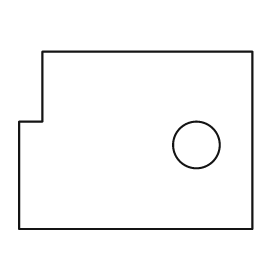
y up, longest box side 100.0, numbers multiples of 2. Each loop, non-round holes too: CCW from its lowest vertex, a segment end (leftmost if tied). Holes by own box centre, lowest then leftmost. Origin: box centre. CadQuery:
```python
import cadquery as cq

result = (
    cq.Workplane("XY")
    .moveTo(-50.0, -38.0)
    .lineTo(50.0, -38.0)
    .lineTo(50.0, 38.0)
    .lineTo(-40.0, 38.0)
    .lineTo(-40.0, 8.0)
    .lineTo(-50.0, 8.0)
    .close()
    .moveTo(26.0, -2.0)
    .circle(10.0)
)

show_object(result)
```